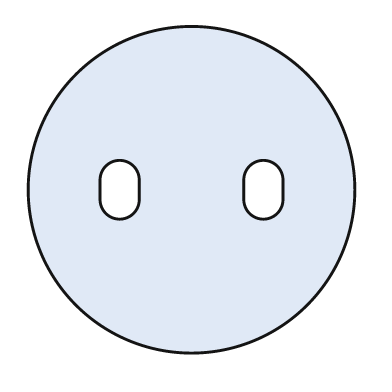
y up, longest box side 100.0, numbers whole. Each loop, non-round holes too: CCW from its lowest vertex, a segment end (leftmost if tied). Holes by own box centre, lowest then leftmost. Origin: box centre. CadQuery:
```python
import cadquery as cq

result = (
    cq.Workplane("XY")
    .moveTo(0.0, 0.0)
    .circle(50.0)
    .moveTo(-28.0, -3.0)
    .threePointArc((-22.0, -9.0), (-16.0, -3.0))
    .lineTo(-16.0, 3.0)
    .threePointArc((-22.0, 9.0), (-28.0, 3.0))
    .close()
    .moveTo(16.0, -3.0)
    .threePointArc((22.0, -9.0), (28.0, -3.0))
    .lineTo(28.0, 3.0)
    .threePointArc((22.0, 9.0), (16.0, 3.0))
    .close()
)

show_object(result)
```